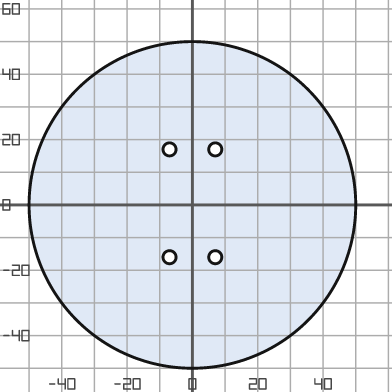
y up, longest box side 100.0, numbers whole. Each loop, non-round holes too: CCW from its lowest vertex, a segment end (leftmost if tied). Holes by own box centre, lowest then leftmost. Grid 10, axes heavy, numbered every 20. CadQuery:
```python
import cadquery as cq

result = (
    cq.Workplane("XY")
    .moveTo(0.0, 0.0)
    .circle(50.0)
    .moveTo(-7.0, -16.0)
    .circle(2.0)
    .moveTo(7.0, -16.0)
    .circle(2.0)
    .moveTo(-7.0, 17.0)
    .circle(2.0)
    .moveTo(7.0, 17.0)
    .circle(2.0)
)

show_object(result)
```